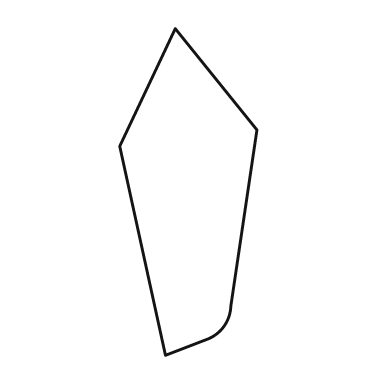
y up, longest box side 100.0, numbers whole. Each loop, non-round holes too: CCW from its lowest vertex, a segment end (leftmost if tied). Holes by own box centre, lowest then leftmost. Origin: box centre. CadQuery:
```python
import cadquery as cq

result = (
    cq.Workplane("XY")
    .moveTo(-7.0, -50.0)
    .lineTo(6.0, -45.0)
    .threePointArc((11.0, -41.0), (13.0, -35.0))
    .lineTo(21.0, 19.0)
    .lineTo(-4.0, 50.0)
    .lineTo(-21.0, 14.0)
    .close()
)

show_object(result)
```